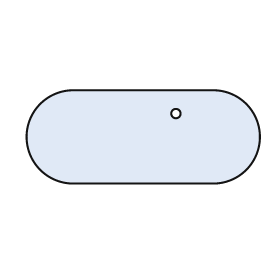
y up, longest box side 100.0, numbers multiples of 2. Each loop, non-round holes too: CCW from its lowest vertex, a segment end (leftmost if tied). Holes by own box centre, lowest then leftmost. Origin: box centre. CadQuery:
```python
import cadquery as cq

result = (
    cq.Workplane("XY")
    .moveTo(-30.0, -20.0)
    .lineTo(30.0, -20.0)
    .threePointArc((50.0, 0.0), (30.0, 20.0))
    .lineTo(-30.0, 20.0)
    .threePointArc((-50.0, 0.0), (-30.0, -20.0))
    .close()
    .moveTo(14.0, 10.0)
    .circle(2.0)
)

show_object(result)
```